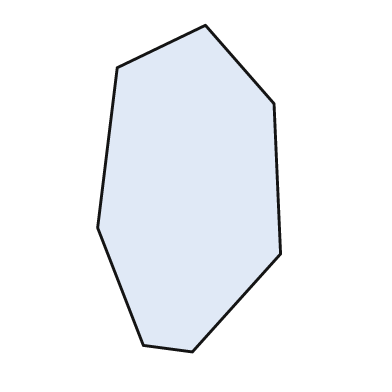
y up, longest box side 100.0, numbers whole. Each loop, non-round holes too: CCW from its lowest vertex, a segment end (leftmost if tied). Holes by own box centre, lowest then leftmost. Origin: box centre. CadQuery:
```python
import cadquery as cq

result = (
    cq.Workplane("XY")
    .moveTo(1.0, -50.0)
    .lineTo(28.0, -20.0)
    .lineTo(26.0, 26.0)
    .lineTo(5.0, 50.0)
    .lineTo(-22.0, 37.0)
    .lineTo(-28.0, -12.0)
    .lineTo(-14.0, -48.0)
    .close()
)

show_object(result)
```